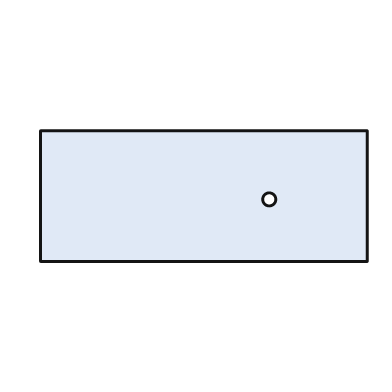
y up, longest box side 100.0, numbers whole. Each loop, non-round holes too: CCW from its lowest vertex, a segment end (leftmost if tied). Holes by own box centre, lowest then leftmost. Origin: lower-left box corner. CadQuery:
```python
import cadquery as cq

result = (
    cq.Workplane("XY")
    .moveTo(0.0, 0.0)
    .lineTo(100.0, 0.0)
    .lineTo(100.0, 40.0)
    .lineTo(0.0, 40.0)
    .close()
    .moveTo(70.0, 19.0)
    .circle(2.0)
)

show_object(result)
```